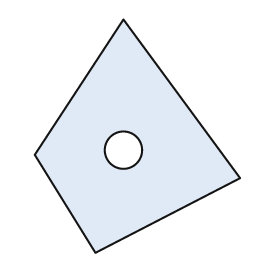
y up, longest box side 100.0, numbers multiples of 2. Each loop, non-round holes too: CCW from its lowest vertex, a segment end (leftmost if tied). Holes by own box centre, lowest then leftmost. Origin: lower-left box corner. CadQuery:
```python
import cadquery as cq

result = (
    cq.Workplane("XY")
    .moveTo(26.0, 0.0)
    .lineTo(88.0, 32.0)
    .lineTo(38.0, 100.0)
    .lineTo(0.0, 42.0)
    .close()
    .moveTo(38.0, 44.0)
    .circle(8.0)
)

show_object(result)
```